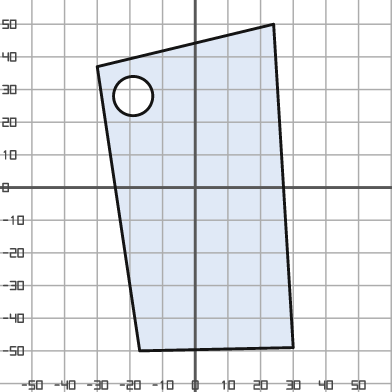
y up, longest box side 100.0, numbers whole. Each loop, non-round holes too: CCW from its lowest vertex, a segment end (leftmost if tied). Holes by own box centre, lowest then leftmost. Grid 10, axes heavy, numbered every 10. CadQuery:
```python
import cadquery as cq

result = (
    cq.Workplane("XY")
    .moveTo(-17.0, -50.0)
    .lineTo(30.0, -49.0)
    .lineTo(24.0, 50.0)
    .lineTo(-30.0, 37.0)
    .close()
    .moveTo(-19.0, 28.0)
    .circle(6.0)
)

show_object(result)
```